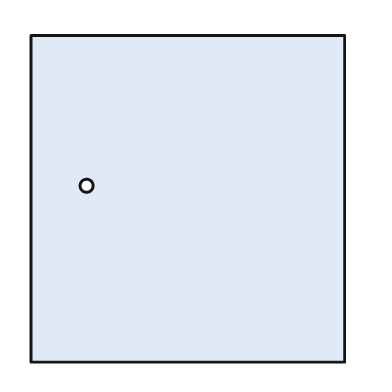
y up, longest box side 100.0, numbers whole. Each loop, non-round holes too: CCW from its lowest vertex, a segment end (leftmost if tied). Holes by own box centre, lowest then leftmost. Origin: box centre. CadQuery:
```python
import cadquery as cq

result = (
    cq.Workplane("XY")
    .moveTo(-48.0, -50.0)
    .lineTo(48.0, -50.0)
    .lineTo(48.0, 50.0)
    .lineTo(-48.0, 50.0)
    .close()
    .moveTo(-31.0, 4.0)
    .circle(2.0)
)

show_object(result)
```